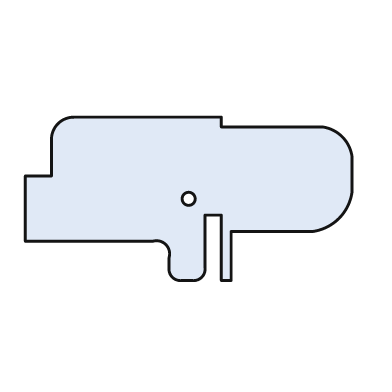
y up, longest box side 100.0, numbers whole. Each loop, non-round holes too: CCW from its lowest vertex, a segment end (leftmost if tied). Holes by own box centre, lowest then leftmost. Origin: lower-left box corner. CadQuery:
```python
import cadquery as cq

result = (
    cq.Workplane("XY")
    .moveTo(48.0, 0.0)
    .lineTo(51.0, 0.0)
    .threePointArc((54.0, 1.0), (55.0, 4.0))
    .lineTo(55.0, 20.0)
    .lineTo(60.0, 20.0)
    .lineTo(60.0, 0.0)
    .lineTo(63.0, 0.0)
    .lineTo(63.0, 15.0)
    .lineTo(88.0, 15.0)
    .threePointArc((96.0, 19.0), (100.0, 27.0))
    .lineTo(100.0, 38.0)
    .threePointArc((97.0, 44.0), (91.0, 47.0))
    .lineTo(60.0, 47.0)
    .lineTo(60.0, 50.0)
    .lineTo(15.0, 50.0)
    .threePointArc((10.0, 48.0), (8.0, 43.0))
    .lineTo(8.0, 32.0)
    .lineTo(0.0, 32.0)
    .lineTo(0.0, 12.0)
    .lineTo(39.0, 12.0)
    .threePointArc((43.0, 11.0), (44.0, 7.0))
    .lineTo(44.0, 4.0)
    .threePointArc((45.0, 1.0), (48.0, 0.0))
    .close()
    .moveTo(50.0, 25.0)
    .circle(2.0)
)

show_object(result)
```